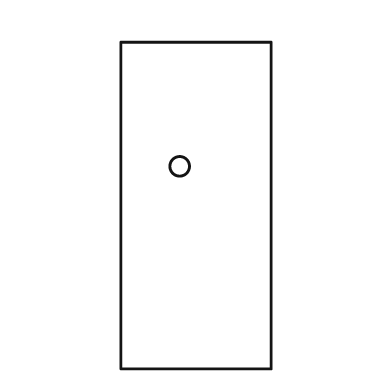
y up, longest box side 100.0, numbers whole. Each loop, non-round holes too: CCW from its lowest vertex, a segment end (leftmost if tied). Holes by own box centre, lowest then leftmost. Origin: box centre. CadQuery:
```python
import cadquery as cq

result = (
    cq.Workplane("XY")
    .moveTo(-23.0, -50.0)
    .lineTo(23.0, -50.0)
    .lineTo(23.0, 50.0)
    .lineTo(-23.0, 50.0)
    .close()
    .moveTo(-5.0, 12.0)
    .circle(3.0)
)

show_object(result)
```